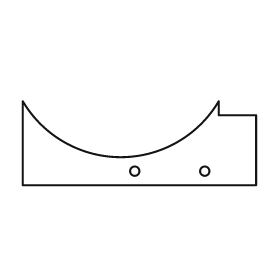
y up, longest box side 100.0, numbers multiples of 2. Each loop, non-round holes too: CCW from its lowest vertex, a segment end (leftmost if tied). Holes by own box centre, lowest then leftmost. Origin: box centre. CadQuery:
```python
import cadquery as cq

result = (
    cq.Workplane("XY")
    .moveTo(-50.0, -18.0)
    .lineTo(50.0, -18.0)
    .lineTo(50.0, 12.0)
    .lineTo(34.0, 12.0)
    .lineTo(34.0, 18.0)
    .threePointArc((-8.0, -6.0), (-50.0, 18.0))
    .close()
    .moveTo(-2.0, -12.0)
    .circle(2.0)
    .moveTo(28.0, -12.0)
    .circle(2.0)
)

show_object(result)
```